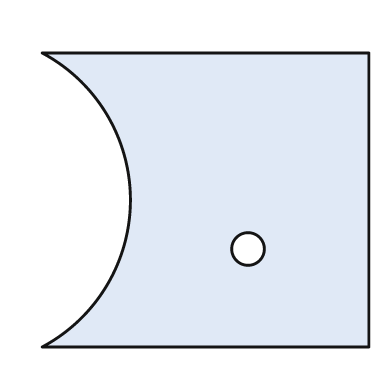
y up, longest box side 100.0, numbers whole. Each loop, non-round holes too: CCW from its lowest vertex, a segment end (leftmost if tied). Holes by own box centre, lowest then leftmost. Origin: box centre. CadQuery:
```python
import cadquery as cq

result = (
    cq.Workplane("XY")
    .moveTo(-50.0, -45.0)
    .lineTo(50.0, -45.0)
    .lineTo(50.0, 45.0)
    .lineTo(-50.0, 45.0)
    .threePointArc((-23.0, 0.0), (-50.0, -45.0))
    .close()
    .moveTo(13.0, -15.0)
    .circle(5.0)
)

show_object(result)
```